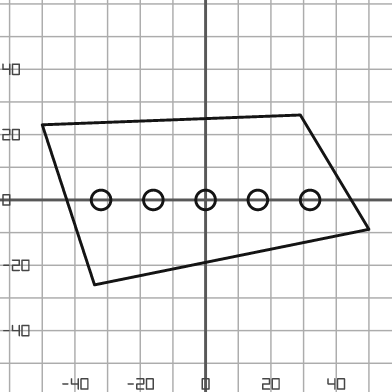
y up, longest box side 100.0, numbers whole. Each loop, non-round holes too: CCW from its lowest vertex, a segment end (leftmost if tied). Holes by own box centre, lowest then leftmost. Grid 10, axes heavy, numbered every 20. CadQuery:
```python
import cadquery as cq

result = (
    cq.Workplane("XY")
    .moveTo(-34.0, -26.0)
    .lineTo(50.0, -9.0)
    .lineTo(29.0, 26.0)
    .lineTo(-50.0, 23.0)
    .close()
    .moveTo(-32.0, 0.0)
    .circle(3.0)
    .moveTo(-16.0, 0.0)
    .circle(3.0)
    .moveTo(0.0, 0.0)
    .circle(3.0)
    .moveTo(16.0, 0.0)
    .circle(3.0)
    .moveTo(32.0, 0.0)
    .circle(3.0)
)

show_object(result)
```